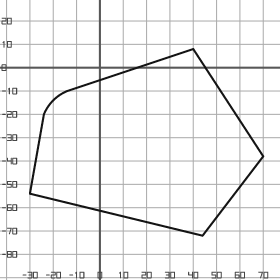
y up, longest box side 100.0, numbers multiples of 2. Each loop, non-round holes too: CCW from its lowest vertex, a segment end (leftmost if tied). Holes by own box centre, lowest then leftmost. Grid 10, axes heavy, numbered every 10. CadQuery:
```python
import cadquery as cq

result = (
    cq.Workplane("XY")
    .moveTo(44.0, -72.0)
    .lineTo(70.0, -38.0)
    .lineTo(40.0, 8.0)
    .lineTo(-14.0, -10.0)
    .threePointArc((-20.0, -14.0), (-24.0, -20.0))
    .lineTo(-30.0, -54.0)
    .close()
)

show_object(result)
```